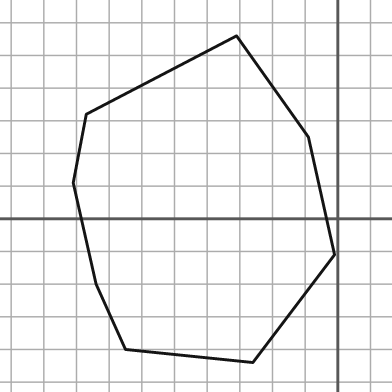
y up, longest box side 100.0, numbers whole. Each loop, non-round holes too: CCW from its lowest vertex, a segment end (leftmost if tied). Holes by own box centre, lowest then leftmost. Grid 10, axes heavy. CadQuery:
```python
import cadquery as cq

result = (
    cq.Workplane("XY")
    .moveTo(-26.0, -44.0)
    .lineTo(-1.0, -11.0)
    .lineTo(-9.0, 25.0)
    .lineTo(-31.0, 56.0)
    .lineTo(-77.0, 32.0)
    .lineTo(-81.0, 11.0)
    .lineTo(-74.0, -20.0)
    .lineTo(-65.0, -40.0)
    .close()
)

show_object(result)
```